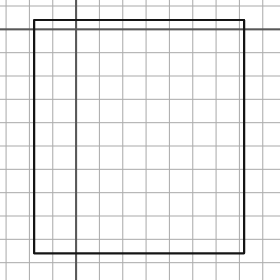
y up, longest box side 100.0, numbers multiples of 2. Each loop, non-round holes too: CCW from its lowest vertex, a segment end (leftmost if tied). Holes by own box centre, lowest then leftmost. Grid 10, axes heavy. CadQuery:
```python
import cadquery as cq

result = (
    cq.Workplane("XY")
    .moveTo(-18.0, -96.0)
    .lineTo(72.0, -96.0)
    .lineTo(72.0, 4.0)
    .lineTo(-18.0, 4.0)
    .close()
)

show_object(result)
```